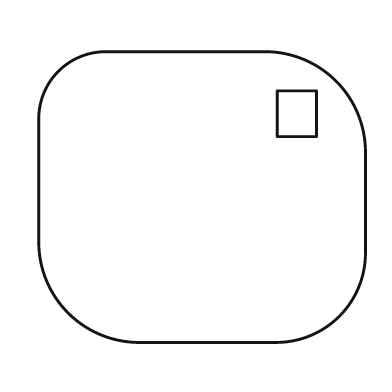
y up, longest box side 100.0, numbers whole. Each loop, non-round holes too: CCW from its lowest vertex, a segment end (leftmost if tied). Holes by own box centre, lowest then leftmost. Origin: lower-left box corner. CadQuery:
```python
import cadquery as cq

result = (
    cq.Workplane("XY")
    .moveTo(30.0, 0.0)
    .lineTo(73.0, 0.0)
    .threePointArc((92.0, 8.0), (100.0, 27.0))
    .lineTo(100.0, 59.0)
    .threePointArc((91.0, 80.0), (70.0, 89.0))
    .lineTo(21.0, 89.0)
    .threePointArc((6.0, 83.0), (0.0, 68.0))
    .lineTo(0.0, 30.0)
    .threePointArc((9.0, 9.0), (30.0, 0.0))
    .close()
    .moveTo(73.0, 63.0)
    .lineTo(85.0, 63.0)
    .lineTo(85.0, 77.0)
    .lineTo(73.0, 77.0)
    .close()
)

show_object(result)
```